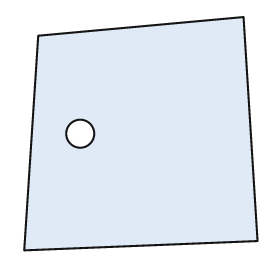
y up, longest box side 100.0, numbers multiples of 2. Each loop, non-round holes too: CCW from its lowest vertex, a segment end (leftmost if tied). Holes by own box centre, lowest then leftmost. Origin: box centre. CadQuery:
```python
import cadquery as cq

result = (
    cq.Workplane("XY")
    .moveTo(-50.0, -50.0)
    .lineTo(50.0, -46.0)
    .lineTo(44.0, 50.0)
    .lineTo(-44.0, 42.0)
    .close()
    .moveTo(-26.0, 0.0)
    .circle(6.0)
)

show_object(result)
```